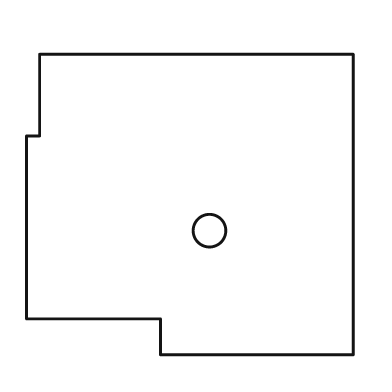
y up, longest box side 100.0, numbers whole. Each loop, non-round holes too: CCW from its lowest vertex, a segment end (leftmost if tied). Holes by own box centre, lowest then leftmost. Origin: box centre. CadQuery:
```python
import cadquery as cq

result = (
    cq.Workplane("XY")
    .moveTo(-9.0, -46.0)
    .lineTo(50.0, -46.0)
    .lineTo(50.0, 46.0)
    .lineTo(-46.0, 46.0)
    .lineTo(-46.0, 21.0)
    .lineTo(-50.0, 21.0)
    .lineTo(-50.0, -35.0)
    .lineTo(-9.0, -35.0)
    .close()
    .moveTo(6.0, -8.0)
    .circle(5.0)
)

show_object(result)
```